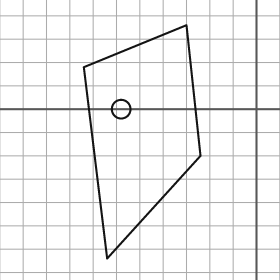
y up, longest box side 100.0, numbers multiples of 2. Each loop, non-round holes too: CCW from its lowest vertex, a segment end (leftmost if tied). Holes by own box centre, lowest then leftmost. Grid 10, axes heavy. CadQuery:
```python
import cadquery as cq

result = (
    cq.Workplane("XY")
    .moveTo(-64.0, -64.0)
    .lineTo(-24.0, -20.0)
    .lineTo(-30.0, 36.0)
    .lineTo(-74.0, 18.0)
    .close()
    .moveTo(-58.0, 0.0)
    .circle(4.0)
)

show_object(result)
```